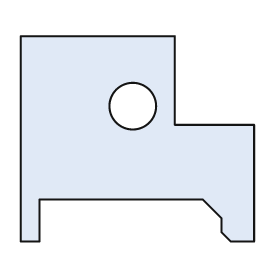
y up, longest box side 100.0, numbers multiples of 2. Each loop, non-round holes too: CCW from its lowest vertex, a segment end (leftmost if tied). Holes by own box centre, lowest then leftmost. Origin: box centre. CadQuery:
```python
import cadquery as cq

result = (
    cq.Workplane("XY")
    .moveTo(-50.0, -44.0)
    .lineTo(-42.0, -44.0)
    .lineTo(-42.0, -26.0)
    .lineTo(28.0, -26.0)
    .lineTo(36.0, -34.0)
    .lineTo(36.0, -40.0)
    .lineTo(40.0, -44.0)
    .lineTo(50.0, -44.0)
    .lineTo(50.0, 6.0)
    .lineTo(16.0, 6.0)
    .lineTo(16.0, 44.0)
    .lineTo(-50.0, 44.0)
    .close()
    .moveTo(-2.0, 14.0)
    .circle(10.0)
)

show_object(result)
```